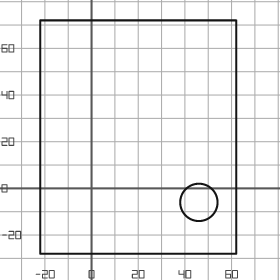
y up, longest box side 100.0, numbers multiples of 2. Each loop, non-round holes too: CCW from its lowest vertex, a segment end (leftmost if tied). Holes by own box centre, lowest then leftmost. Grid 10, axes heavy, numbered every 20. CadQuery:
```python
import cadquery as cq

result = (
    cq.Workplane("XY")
    .moveTo(-22.0, -28.0)
    .lineTo(62.0, -28.0)
    .lineTo(62.0, 72.0)
    .lineTo(-22.0, 72.0)
    .close()
    .moveTo(46.0, -6.0)
    .circle(8.0)
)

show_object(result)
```